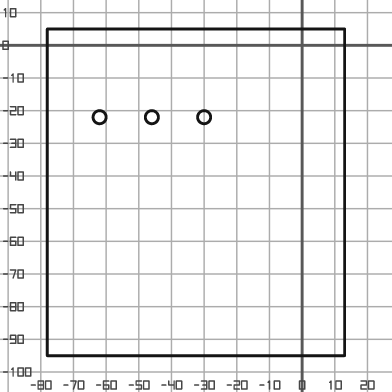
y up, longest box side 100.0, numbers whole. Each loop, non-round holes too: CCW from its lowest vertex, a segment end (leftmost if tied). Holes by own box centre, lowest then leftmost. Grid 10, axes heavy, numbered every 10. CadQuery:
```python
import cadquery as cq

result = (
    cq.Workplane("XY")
    .moveTo(-78.0, -95.0)
    .lineTo(13.0, -95.0)
    .lineTo(13.0, 5.0)
    .lineTo(-78.0, 5.0)
    .close()
    .moveTo(-62.0, -22.0)
    .circle(2.0)
    .moveTo(-46.0, -22.0)
    .circle(2.0)
    .moveTo(-30.0, -22.0)
    .circle(2.0)
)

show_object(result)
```